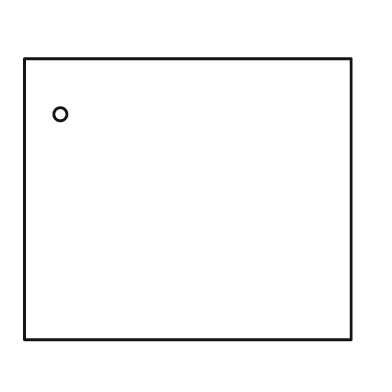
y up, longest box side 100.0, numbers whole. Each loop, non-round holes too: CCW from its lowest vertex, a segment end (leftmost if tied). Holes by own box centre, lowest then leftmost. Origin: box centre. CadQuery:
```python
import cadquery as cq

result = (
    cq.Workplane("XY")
    .moveTo(-50.0, -43.0)
    .lineTo(50.0, -43.0)
    .lineTo(50.0, 43.0)
    .lineTo(-50.0, 43.0)
    .close()
    .moveTo(-39.0, 26.0)
    .circle(2.0)
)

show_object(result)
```